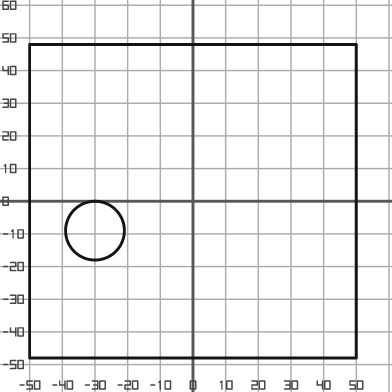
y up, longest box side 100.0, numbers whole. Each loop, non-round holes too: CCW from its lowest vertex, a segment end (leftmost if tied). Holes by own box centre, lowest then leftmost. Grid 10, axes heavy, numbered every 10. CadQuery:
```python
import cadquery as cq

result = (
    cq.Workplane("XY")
    .moveTo(-50.0, -48.0)
    .lineTo(50.0, -48.0)
    .lineTo(50.0, 48.0)
    .lineTo(-50.0, 48.0)
    .close()
    .moveTo(-30.0, -9.0)
    .circle(9.0)
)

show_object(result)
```